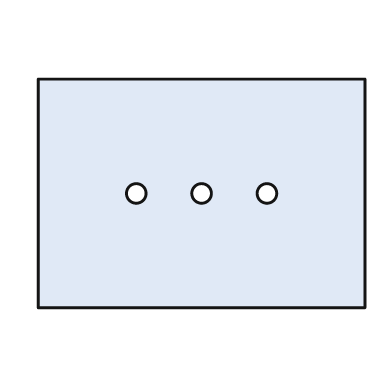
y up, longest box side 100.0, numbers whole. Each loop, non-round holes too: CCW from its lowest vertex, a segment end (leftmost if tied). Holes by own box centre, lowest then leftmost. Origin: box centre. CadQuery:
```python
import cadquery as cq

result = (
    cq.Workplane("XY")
    .moveTo(-50.0, -35.0)
    .lineTo(50.0, -35.0)
    .lineTo(50.0, 35.0)
    .lineTo(-50.0, 35.0)
    .close()
    .moveTo(-20.0, 0.0)
    .circle(3.0)
    .moveTo(0.0, 0.0)
    .circle(3.0)
    .moveTo(20.0, 0.0)
    .circle(3.0)
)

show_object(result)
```